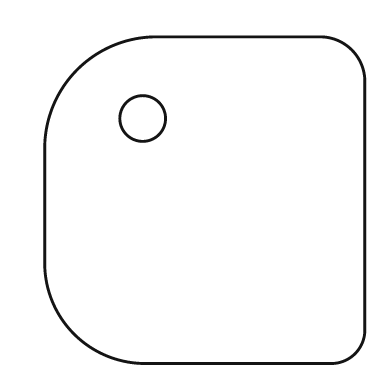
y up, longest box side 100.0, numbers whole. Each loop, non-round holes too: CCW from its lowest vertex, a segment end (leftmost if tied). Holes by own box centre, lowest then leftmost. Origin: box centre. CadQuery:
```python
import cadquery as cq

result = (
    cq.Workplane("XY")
    .moveTo(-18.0, -50.0)
    .lineTo(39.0, -50.0)
    .threePointArc((46.0, -47.0), (49.0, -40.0))
    .lineTo(49.0, 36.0)
    .threePointArc((45.0, 46.0), (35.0, 50.0))
    .lineTo(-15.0, 50.0)
    .threePointArc((-39.0, 40.0), (-49.0, 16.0))
    .lineTo(-49.0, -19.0)
    .threePointArc((-40.0, -41.0), (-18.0, -50.0))
    .close()
    .moveTo(-19.0, 25.0)
    .circle(7.0)
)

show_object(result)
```